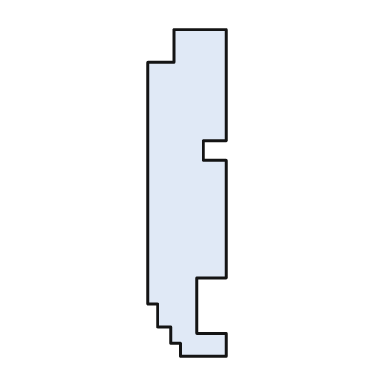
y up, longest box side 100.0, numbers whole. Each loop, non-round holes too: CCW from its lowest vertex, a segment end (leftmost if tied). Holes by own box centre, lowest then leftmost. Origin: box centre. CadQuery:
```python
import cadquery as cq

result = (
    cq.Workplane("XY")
    .moveTo(-2.0, -50.0)
    .lineTo(12.0, -50.0)
    .lineTo(12.0, -43.0)
    .lineTo(3.0, -43.0)
    .lineTo(3.0, -26.0)
    .lineTo(12.0, -26.0)
    .lineTo(12.0, 10.0)
    .lineTo(5.0, 10.0)
    .lineTo(5.0, 16.0)
    .lineTo(12.0, 16.0)
    .lineTo(12.0, 50.0)
    .lineTo(-4.0, 50.0)
    .lineTo(-4.0, 40.0)
    .lineTo(-12.0, 40.0)
    .lineTo(-12.0, -34.0)
    .lineTo(-9.0, -34.0)
    .lineTo(-9.0, -41.0)
    .lineTo(-5.0, -41.0)
    .lineTo(-5.0, -46.0)
    .lineTo(-2.0, -46.0)
    .close()
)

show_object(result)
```